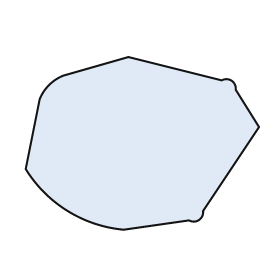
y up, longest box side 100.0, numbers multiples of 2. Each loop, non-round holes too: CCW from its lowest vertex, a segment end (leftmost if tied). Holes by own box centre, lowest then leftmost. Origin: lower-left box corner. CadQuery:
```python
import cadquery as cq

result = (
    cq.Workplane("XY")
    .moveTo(42.0, 0.0)
    .lineTo(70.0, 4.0)
    .threePointArc((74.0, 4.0), (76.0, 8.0))
    .lineTo(100.0, 44.0)
    .lineTo(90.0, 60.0)
    .threePointArc((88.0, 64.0), (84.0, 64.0))
    .lineTo(44.0, 74.0)
    .lineTo(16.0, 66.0)
    .threePointArc((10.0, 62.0), (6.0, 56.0))
    .lineTo(0.0, 26.0)
    .threePointArc((18.0, 8.0), (42.0, 0.0))
    .close()
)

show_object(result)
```